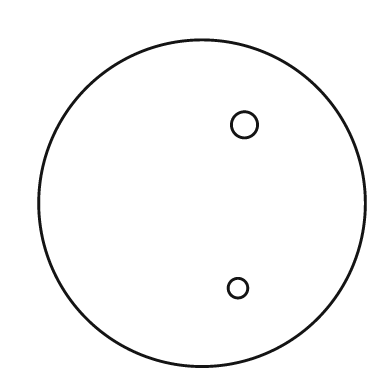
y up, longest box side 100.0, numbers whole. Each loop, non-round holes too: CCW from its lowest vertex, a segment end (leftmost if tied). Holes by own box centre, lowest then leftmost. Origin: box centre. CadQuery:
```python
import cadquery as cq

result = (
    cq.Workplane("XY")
    .moveTo(0.0, 0.0)
    .circle(50.0)
    .moveTo(11.0, -26.0)
    .circle(3.0)
    .moveTo(13.0, 24.0)
    .circle(4.0)
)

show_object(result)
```